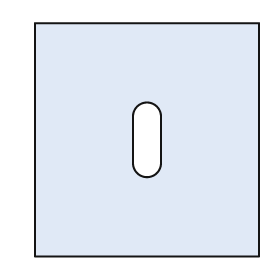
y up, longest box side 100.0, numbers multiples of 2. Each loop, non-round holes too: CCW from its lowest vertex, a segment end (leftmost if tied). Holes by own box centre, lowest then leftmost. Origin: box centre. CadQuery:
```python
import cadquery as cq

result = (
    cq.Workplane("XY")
    .moveTo(-48.0, -50.0)
    .lineTo(48.0, -50.0)
    .lineTo(48.0, 50.0)
    .lineTo(-48.0, 50.0)
    .close()
    .moveTo(-6.0, -10.0)
    .threePointArc((0.0, -16.0), (6.0, -10.0))
    .lineTo(6.0, 10.0)
    .threePointArc((0.0, 16.0), (-6.0, 10.0))
    .close()
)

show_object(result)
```